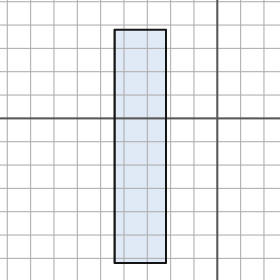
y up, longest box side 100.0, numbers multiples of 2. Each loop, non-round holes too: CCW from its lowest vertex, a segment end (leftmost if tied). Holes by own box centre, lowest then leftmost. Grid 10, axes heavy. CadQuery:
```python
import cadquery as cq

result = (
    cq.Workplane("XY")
    .moveTo(-44.0, -62.0)
    .lineTo(-22.0, -62.0)
    .lineTo(-22.0, 38.0)
    .lineTo(-44.0, 38.0)
    .close()
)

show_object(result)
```